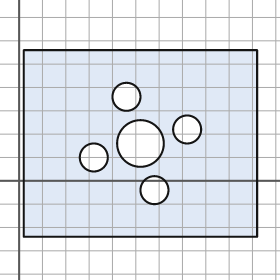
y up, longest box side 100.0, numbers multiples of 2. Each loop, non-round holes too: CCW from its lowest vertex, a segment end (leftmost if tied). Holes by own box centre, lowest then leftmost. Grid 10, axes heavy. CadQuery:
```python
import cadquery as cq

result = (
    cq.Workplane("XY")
    .moveTo(2.0, -24.0)
    .lineTo(102.0, -24.0)
    .lineTo(102.0, 56.0)
    .lineTo(2.0, 56.0)
    .close()
    .moveTo(58.0, -4.0)
    .circle(6.0)
    .moveTo(32.0, 10.0)
    .circle(6.0)
    .moveTo(52.0, 16.0)
    .circle(10.0)
    .moveTo(72.0, 22.0)
    .circle(6.0)
    .moveTo(46.0, 36.0)
    .circle(6.0)
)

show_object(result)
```